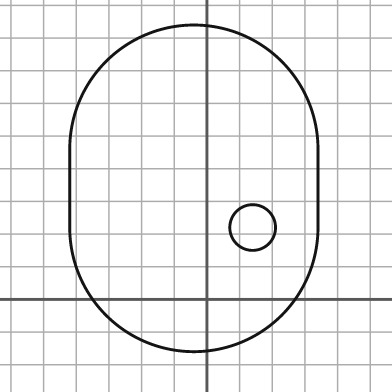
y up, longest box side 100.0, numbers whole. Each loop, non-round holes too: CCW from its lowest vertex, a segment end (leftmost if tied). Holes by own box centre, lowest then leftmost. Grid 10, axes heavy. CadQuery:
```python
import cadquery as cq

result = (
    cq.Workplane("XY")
    .moveTo(-42.0, 22.0)
    .threePointArc((-4.0, -16.0), (34.0, 22.0))
    .lineTo(34.0, 46.0)
    .threePointArc((-4.0, 84.0), (-42.0, 46.0))
    .close()
    .moveTo(14.0, 22.0)
    .circle(7.0)
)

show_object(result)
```